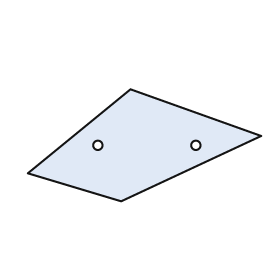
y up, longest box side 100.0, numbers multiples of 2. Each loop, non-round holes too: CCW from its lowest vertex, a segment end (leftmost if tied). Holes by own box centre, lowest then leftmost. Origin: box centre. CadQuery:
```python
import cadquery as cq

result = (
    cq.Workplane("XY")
    .moveTo(-10.0, -24.0)
    .lineTo(50.0, 4.0)
    .lineTo(-6.0, 24.0)
    .lineTo(-50.0, -12.0)
    .close()
    .moveTo(-20.0, 0.0)
    .circle(2.0)
    .moveTo(22.0, 0.0)
    .circle(2.0)
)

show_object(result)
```